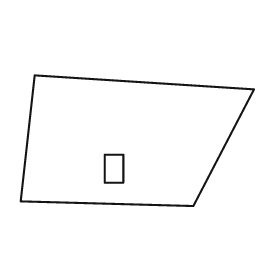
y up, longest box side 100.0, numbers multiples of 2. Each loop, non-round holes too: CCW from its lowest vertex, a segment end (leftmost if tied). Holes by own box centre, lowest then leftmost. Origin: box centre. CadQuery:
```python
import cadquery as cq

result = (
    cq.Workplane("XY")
    .moveTo(24.0, -28.0)
    .lineTo(50.0, 22.0)
    .lineTo(-44.0, 28.0)
    .lineTo(-50.0, -26.0)
    .close()
    .moveTo(-14.0, -18.0)
    .lineTo(-6.0, -18.0)
    .lineTo(-6.0, -6.0)
    .lineTo(-14.0, -6.0)
    .close()
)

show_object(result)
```